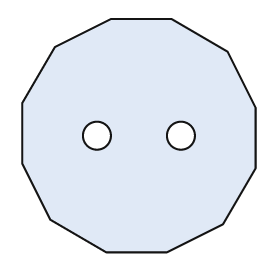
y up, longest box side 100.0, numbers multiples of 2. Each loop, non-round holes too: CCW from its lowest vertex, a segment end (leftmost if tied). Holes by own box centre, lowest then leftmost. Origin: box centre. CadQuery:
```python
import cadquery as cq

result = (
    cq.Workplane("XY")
    .moveTo(-14.0, -50.0)
    .lineTo(12.0, -50.0)
    .lineTo(36.0, -38.0)
    .lineTo(50.0, -14.0)
    .lineTo(50.0, 12.0)
    .lineTo(38.0, 36.0)
    .lineTo(14.0, 50.0)
    .lineTo(-12.0, 50.0)
    .lineTo(-36.0, 38.0)
    .lineTo(-50.0, 14.0)
    .lineTo(-50.0, -12.0)
    .lineTo(-38.0, -36.0)
    .close()
    .moveTo(-18.0, 0.0)
    .circle(6.0)
    .moveTo(18.0, 0.0)
    .circle(6.0)
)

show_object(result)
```